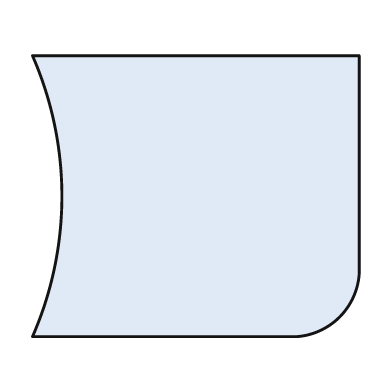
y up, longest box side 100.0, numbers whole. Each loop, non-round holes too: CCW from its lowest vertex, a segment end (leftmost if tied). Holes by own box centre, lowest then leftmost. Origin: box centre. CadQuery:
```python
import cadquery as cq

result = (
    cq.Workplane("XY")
    .moveTo(-50.0, -43.0)
    .lineTo(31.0, -43.0)
    .threePointArc((44.0, -37.0), (50.0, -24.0))
    .lineTo(50.0, 43.0)
    .lineTo(-50.0, 43.0)
    .threePointArc((-41.0, 0.0), (-50.0, -43.0))
    .close()
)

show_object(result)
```